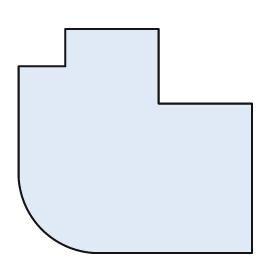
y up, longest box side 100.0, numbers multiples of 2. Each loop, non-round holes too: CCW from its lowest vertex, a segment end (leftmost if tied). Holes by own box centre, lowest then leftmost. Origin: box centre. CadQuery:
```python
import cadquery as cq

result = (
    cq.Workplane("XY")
    .moveTo(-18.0, -48.0)
    .lineTo(50.0, -48.0)
    .lineTo(50.0, 16.0)
    .lineTo(10.0, 16.0)
    .lineTo(10.0, 48.0)
    .lineTo(-30.0, 48.0)
    .lineTo(-30.0, 32.0)
    .lineTo(-50.0, 32.0)
    .lineTo(-50.0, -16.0)
    .threePointArc((-40.0, -38.0), (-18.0, -48.0))
    .close()
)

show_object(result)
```